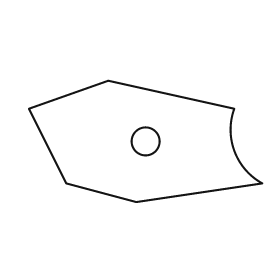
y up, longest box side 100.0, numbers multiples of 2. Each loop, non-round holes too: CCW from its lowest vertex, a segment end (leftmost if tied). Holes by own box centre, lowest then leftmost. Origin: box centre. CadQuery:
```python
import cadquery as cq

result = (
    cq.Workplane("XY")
    .moveTo(-4.0, -26.0)
    .lineTo(50.0, -18.0)
    .threePointArc((38.0, -4.0), (38.0, 14.0))
    .lineTo(-16.0, 26.0)
    .lineTo(-50.0, 14.0)
    .lineTo(-34.0, -18.0)
    .close()
    .moveTo(0.0, 0.0)
    .circle(6.0)
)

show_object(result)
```